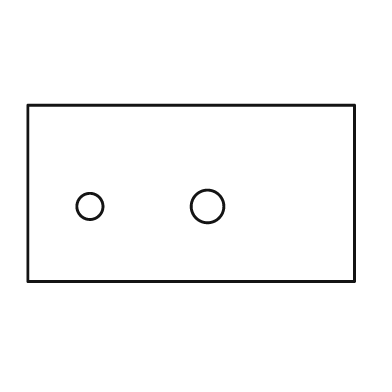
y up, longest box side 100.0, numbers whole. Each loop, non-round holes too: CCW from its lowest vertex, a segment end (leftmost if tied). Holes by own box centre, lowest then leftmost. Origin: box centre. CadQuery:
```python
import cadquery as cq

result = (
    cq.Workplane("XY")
    .moveTo(-50.0, -27.0)
    .lineTo(50.0, -27.0)
    .lineTo(50.0, 27.0)
    .lineTo(-50.0, 27.0)
    .close()
    .moveTo(-31.0, -4.0)
    .circle(4.0)
    .moveTo(5.0, -4.0)
    .circle(5.0)
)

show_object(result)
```